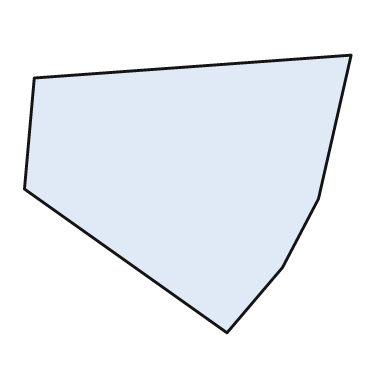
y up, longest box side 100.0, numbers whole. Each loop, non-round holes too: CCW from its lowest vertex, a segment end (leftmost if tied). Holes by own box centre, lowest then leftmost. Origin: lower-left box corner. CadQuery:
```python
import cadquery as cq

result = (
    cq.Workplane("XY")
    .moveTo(62.0, 0.0)
    .lineTo(79.0, 20.0)
    .lineTo(90.0, 41.0)
    .lineTo(100.0, 85.0)
    .lineTo(3.0, 78.0)
    .lineTo(0.0, 44.0)
    .close()
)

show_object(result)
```